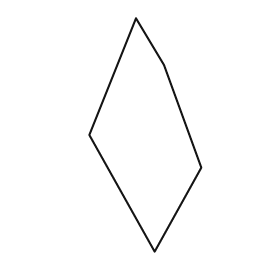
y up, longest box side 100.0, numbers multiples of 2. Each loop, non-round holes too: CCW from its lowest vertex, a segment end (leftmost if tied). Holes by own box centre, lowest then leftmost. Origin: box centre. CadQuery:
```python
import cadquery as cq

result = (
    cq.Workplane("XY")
    .moveTo(4.0, -50.0)
    .lineTo(24.0, -14.0)
    .lineTo(8.0, 30.0)
    .lineTo(-4.0, 50.0)
    .lineTo(-24.0, 0.0)
    .close()
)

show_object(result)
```